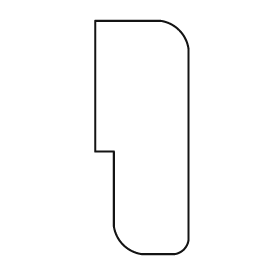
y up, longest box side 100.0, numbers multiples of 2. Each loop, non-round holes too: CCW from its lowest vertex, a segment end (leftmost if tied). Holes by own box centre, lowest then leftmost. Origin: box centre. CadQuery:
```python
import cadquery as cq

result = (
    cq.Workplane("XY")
    .moveTo(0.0, -50.0)
    .lineTo(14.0, -50.0)
    .threePointArc((18.0, -48.0), (20.0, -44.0))
    .lineTo(20.0, 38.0)
    .threePointArc((16.0, 46.0), (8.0, 50.0))
    .lineTo(-20.0, 50.0)
    .lineTo(-20.0, -6.0)
    .lineTo(-12.0, -6.0)
    .lineTo(-12.0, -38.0)
    .threePointArc((-8.0, -46.0), (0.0, -50.0))
    .close()
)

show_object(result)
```